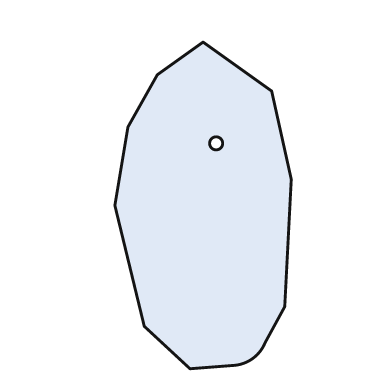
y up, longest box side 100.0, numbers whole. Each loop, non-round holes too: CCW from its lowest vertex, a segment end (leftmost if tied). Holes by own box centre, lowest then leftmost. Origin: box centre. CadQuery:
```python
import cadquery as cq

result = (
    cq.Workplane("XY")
    .moveTo(-4.0, -50.0)
    .lineTo(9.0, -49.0)
    .threePointArc((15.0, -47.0), (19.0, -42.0))
    .lineTo(25.0, -31.0)
    .lineTo(27.0, 8.0)
    .lineTo(21.0, 35.0)
    .lineTo(0.0, 50.0)
    .lineTo(-14.0, 40.0)
    .lineTo(-23.0, 24.0)
    .lineTo(-27.0, 0.0)
    .lineTo(-18.0, -37.0)
    .close()
    .moveTo(4.0, 19.0)
    .circle(2.0)
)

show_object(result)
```